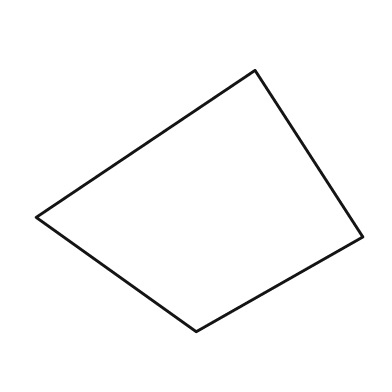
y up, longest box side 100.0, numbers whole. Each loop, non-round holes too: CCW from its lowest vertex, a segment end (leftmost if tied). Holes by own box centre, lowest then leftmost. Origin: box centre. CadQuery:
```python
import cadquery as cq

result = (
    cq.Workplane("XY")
    .moveTo(-1.0, -40.0)
    .lineTo(50.0, -11.0)
    .lineTo(17.0, 40.0)
    .lineTo(-50.0, -5.0)
    .close()
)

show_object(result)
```